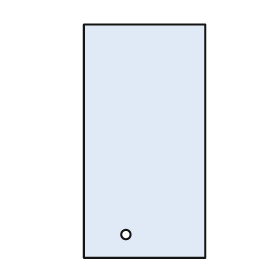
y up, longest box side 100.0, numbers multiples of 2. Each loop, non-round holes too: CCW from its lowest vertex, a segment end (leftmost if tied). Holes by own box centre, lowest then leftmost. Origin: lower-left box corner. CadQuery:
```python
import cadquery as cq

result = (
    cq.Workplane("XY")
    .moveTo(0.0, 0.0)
    .lineTo(52.0, 0.0)
    .lineTo(52.0, 100.0)
    .lineTo(0.0, 100.0)
    .close()
    .moveTo(18.0, 10.0)
    .circle(2.0)
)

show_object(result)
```